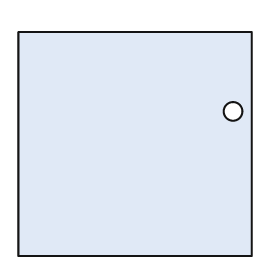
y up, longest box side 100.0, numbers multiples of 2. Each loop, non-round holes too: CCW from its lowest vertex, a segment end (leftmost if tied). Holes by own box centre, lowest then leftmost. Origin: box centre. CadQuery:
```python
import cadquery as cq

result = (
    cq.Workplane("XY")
    .moveTo(-50.0, -48.0)
    .lineTo(50.0, -48.0)
    .lineTo(50.0, 48.0)
    .lineTo(-50.0, 48.0)
    .close()
    .moveTo(42.0, 14.0)
    .circle(4.0)
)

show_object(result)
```